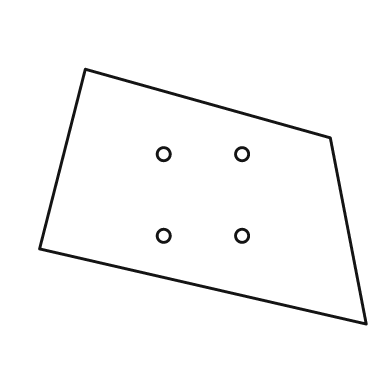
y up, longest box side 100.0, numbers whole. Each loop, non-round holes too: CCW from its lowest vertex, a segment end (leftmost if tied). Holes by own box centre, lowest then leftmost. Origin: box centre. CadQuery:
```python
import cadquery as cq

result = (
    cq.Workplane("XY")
    .moveTo(50.0, -39.0)
    .lineTo(39.0, 18.0)
    .lineTo(-36.0, 39.0)
    .lineTo(-50.0, -16.0)
    .close()
    .moveTo(-12.0, -12.0)
    .circle(2.0)
    .moveTo(12.0, -12.0)
    .circle(2.0)
    .moveTo(-12.0, 13.0)
    .circle(2.0)
    .moveTo(12.0, 13.0)
    .circle(2.0)
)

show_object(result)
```